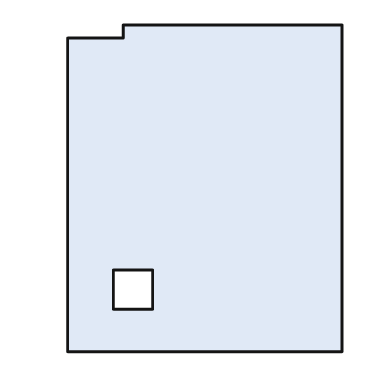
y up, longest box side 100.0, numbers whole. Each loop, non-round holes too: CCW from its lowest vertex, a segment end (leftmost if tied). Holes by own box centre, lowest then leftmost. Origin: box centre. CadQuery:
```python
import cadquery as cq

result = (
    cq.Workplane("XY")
    .moveTo(-42.0, -50.0)
    .lineTo(42.0, -50.0)
    .lineTo(42.0, 50.0)
    .lineTo(-25.0, 50.0)
    .lineTo(-25.0, 46.0)
    .lineTo(-42.0, 46.0)
    .close()
    .moveTo(-28.0, -37.0)
    .lineTo(-16.0, -37.0)
    .lineTo(-16.0, -25.0)
    .lineTo(-28.0, -25.0)
    .close()
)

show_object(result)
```